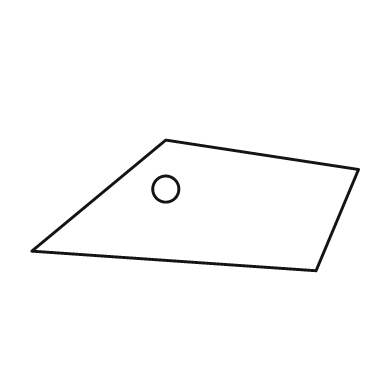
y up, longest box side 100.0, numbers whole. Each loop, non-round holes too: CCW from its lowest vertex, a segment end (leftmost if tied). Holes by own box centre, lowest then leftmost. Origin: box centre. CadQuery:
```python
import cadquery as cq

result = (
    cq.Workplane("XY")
    .moveTo(37.0, -20.0)
    .lineTo(50.0, 11.0)
    .lineTo(-9.0, 20.0)
    .lineTo(-50.0, -14.0)
    .close()
    .moveTo(-9.0, 5.0)
    .circle(4.0)
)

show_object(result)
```